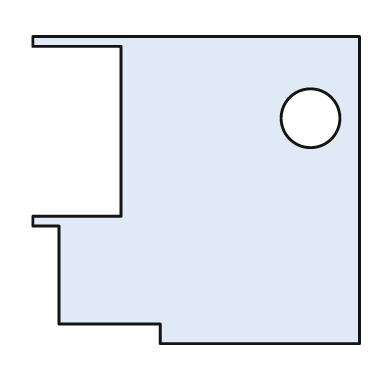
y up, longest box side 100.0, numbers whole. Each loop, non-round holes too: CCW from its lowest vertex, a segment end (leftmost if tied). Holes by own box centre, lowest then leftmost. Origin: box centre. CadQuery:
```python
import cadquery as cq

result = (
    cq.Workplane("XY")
    .moveTo(-11.0, -47.0)
    .lineTo(50.0, -47.0)
    .lineTo(50.0, 47.0)
    .lineTo(-50.0, 47.0)
    .lineTo(-50.0, 44.0)
    .lineTo(-23.0, 44.0)
    .lineTo(-23.0, -8.0)
    .lineTo(-50.0, -8.0)
    .lineTo(-50.0, -11.0)
    .lineTo(-42.0, -11.0)
    .lineTo(-42.0, -41.0)
    .lineTo(-11.0, -41.0)
    .close()
    .moveTo(35.0, 22.0)
    .circle(9.0)
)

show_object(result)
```